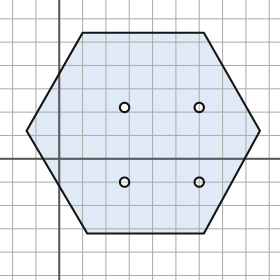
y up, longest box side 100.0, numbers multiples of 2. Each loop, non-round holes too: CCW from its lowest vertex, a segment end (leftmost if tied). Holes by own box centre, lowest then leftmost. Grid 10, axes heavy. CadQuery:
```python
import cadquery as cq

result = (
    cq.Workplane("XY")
    .moveTo(12.0, -32.0)
    .lineTo(62.0, -32.0)
    .lineTo(86.0, 12.0)
    .lineTo(62.0, 54.0)
    .lineTo(10.0, 54.0)
    .lineTo(-14.0, 12.0)
    .close()
    .moveTo(28.0, -10.0)
    .circle(2.0)
    .moveTo(60.0, -10.0)
    .circle(2.0)
    .moveTo(28.0, 22.0)
    .circle(2.0)
    .moveTo(60.0, 22.0)
    .circle(2.0)
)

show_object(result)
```